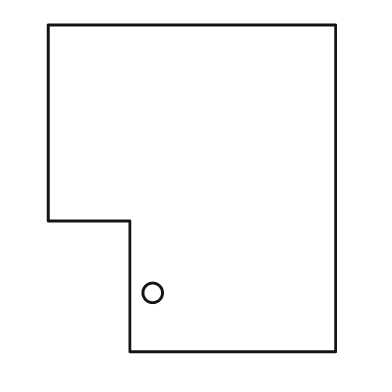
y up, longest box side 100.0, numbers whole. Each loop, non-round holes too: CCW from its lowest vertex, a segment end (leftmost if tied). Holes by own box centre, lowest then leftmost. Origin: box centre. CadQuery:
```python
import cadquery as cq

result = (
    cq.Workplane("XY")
    .moveTo(-19.0, -50.0)
    .lineTo(44.0, -50.0)
    .lineTo(44.0, 50.0)
    .lineTo(-44.0, 50.0)
    .lineTo(-44.0, -10.0)
    .lineTo(-19.0, -10.0)
    .close()
    .moveTo(-12.0, -32.0)
    .circle(3.0)
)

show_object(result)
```